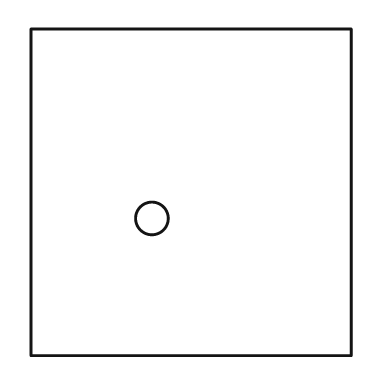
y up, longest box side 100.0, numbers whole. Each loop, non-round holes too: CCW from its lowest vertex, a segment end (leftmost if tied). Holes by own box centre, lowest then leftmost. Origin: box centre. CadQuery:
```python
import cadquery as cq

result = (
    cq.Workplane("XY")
    .moveTo(-49.0, -50.0)
    .lineTo(49.0, -50.0)
    .lineTo(49.0, 50.0)
    .lineTo(-49.0, 50.0)
    .close()
    .moveTo(-12.0, -8.0)
    .circle(5.0)
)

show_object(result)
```